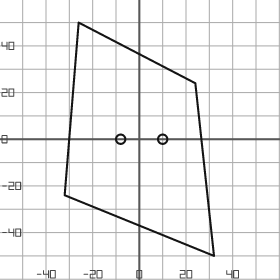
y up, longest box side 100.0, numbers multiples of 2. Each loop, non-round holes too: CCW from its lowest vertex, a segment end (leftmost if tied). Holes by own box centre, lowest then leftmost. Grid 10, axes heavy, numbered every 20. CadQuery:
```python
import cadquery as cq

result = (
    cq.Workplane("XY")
    .moveTo(32.0, -50.0)
    .lineTo(24.0, 24.0)
    .lineTo(-26.0, 50.0)
    .lineTo(-32.0, -24.0)
    .close()
    .moveTo(-8.0, 0.0)
    .circle(2.0)
    .moveTo(10.0, 0.0)
    .circle(2.0)
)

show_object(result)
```